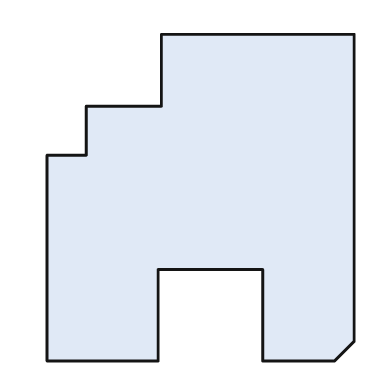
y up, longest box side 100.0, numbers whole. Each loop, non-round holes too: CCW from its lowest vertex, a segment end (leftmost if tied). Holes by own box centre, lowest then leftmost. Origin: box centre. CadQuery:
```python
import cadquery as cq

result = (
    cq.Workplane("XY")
    .moveTo(-47.0, -50.0)
    .lineTo(-13.0, -50.0)
    .lineTo(-13.0, -22.0)
    .lineTo(19.0, -22.0)
    .lineTo(19.0, -50.0)
    .lineTo(41.0, -50.0)
    .lineTo(47.0, -44.0)
    .lineTo(47.0, 50.0)
    .lineTo(-12.0, 50.0)
    .lineTo(-12.0, 28.0)
    .lineTo(-35.0, 28.0)
    .lineTo(-35.0, 13.0)
    .lineTo(-47.0, 13.0)
    .close()
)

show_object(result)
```